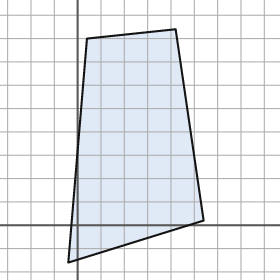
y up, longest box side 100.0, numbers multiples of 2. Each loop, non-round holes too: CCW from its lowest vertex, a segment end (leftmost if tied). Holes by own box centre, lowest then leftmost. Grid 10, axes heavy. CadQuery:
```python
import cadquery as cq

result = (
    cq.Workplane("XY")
    .moveTo(-4.0, -16.0)
    .lineTo(54.0, 2.0)
    .lineTo(42.0, 84.0)
    .lineTo(4.0, 80.0)
    .close()
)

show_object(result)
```